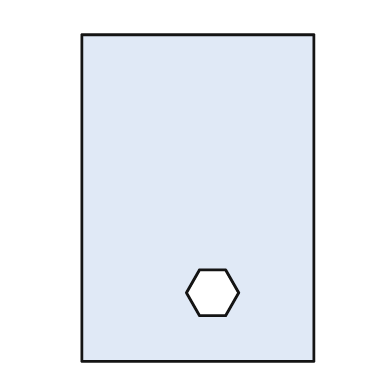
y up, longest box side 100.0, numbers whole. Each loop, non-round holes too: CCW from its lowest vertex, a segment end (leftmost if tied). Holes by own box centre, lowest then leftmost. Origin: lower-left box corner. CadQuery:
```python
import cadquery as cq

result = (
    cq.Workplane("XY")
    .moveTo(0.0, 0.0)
    .lineTo(71.0, 0.0)
    .lineTo(71.0, 100.0)
    .lineTo(0.0, 100.0)
    .close()
    .moveTo(36.0, 14.0)
    .lineTo(44.0, 14.0)
    .lineTo(48.0, 21.0)
    .lineTo(44.0, 28.0)
    .lineTo(36.0, 28.0)
    .lineTo(32.0, 21.0)
    .close()
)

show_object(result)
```